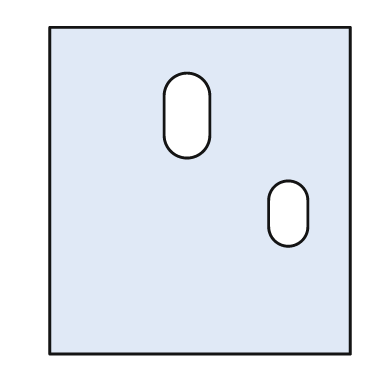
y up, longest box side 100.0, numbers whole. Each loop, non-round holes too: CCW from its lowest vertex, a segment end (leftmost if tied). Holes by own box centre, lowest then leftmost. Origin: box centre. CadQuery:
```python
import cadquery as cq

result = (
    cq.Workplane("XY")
    .moveTo(-46.0, -50.0)
    .lineTo(46.0, -50.0)
    .lineTo(46.0, 50.0)
    .lineTo(-46.0, 50.0)
    .close()
    .moveTo(21.0, -11.0)
    .threePointArc((27.0, -17.0), (33.0, -11.0))
    .lineTo(33.0, -3.0)
    .threePointArc((27.0, 3.0), (21.0, -3.0))
    .close()
    .moveTo(-11.0, 17.0)
    .threePointArc((-4.0, 10.0), (3.0, 17.0))
    .lineTo(3.0, 29.0)
    .threePointArc((-4.0, 36.0), (-11.0, 29.0))
    .close()
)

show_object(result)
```